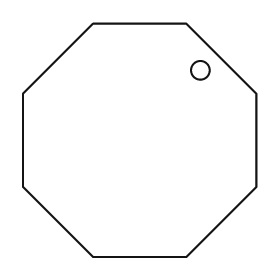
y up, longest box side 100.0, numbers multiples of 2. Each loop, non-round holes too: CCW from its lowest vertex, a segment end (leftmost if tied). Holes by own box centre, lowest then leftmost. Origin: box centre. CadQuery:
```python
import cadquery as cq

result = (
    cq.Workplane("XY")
    .moveTo(-20.0, -50.0)
    .lineTo(20.0, -50.0)
    .lineTo(50.0, -20.0)
    .lineTo(50.0, 20.0)
    .lineTo(20.0, 50.0)
    .lineTo(-20.0, 50.0)
    .lineTo(-50.0, 20.0)
    .lineTo(-50.0, -20.0)
    .close()
    .moveTo(26.0, 30.0)
    .circle(4.0)
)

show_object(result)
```